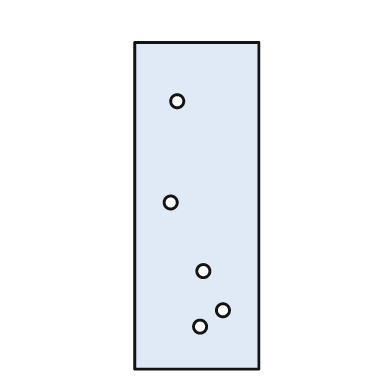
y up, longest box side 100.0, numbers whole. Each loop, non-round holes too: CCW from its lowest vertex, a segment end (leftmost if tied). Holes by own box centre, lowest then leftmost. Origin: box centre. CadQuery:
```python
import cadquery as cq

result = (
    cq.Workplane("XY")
    .moveTo(-19.0, -50.0)
    .lineTo(19.0, -50.0)
    .lineTo(19.0, 50.0)
    .lineTo(-19.0, 50.0)
    .close()
    .moveTo(1.0, -37.0)
    .circle(2.0)
    .moveTo(8.0, -32.0)
    .circle(2.0)
    .moveTo(2.0, -20.0)
    .circle(2.0)
    .moveTo(-8.0, 1.0)
    .circle(2.0)
    .moveTo(-6.0, 32.0)
    .circle(2.0)
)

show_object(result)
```